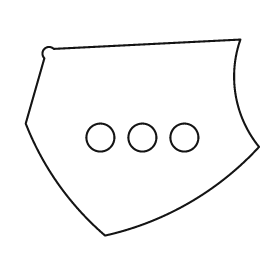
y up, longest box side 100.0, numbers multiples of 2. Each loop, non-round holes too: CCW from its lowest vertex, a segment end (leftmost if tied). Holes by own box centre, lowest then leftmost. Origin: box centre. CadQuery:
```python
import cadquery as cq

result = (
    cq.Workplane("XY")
    .moveTo(-16.0, -42.0)
    .threePointArc((20.0, -28.0), (50.0, -4.0))
    .threePointArc((40.0, 18.0), (42.0, 42.0))
    .lineTo(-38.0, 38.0)
    .threePointArc((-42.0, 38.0), (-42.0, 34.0))
    .lineTo(-50.0, 6.0)
    .threePointArc((-36.0, -20.0), (-16.0, -42.0))
    .close()
    .moveTo(-18.0, 0.0)
    .circle(6.0)
    .moveTo(0.0, 0.0)
    .circle(6.0)
    .moveTo(18.0, 0.0)
    .circle(6.0)
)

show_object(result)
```